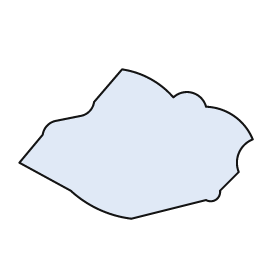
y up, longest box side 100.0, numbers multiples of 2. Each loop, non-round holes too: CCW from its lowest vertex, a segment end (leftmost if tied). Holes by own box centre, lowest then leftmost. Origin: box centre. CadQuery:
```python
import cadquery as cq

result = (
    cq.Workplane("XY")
    .moveTo(-2.0, -32.0)
    .lineTo(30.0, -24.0)
    .threePointArc((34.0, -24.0), (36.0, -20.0))
    .lineTo(44.0, -12.0)
    .threePointArc((44.0, -4.0), (50.0, 2.0))
    .threePointArc((42.0, 12.0), (30.0, 16.0))
    .threePointArc((24.0, 22.0), (16.0, 20.0))
    .threePointArc((6.0, 28.0), (-6.0, 32.0))
    .lineTo(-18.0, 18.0)
    .threePointArc((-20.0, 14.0), (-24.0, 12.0))
    .lineTo(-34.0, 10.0)
    .threePointArc((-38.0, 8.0), (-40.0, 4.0))
    .lineTo(-50.0, -8.0)
    .lineTo(-28.0, -20.0)
    .threePointArc((-16.0, -28.0), (-2.0, -32.0))
    .close()
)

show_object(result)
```